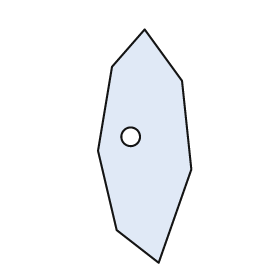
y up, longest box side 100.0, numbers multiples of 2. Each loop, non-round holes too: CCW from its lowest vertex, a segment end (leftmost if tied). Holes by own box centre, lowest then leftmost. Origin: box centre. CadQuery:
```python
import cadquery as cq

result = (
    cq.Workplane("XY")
    .moveTo(6.0, -50.0)
    .lineTo(20.0, -10.0)
    .lineTo(16.0, 28.0)
    .lineTo(0.0, 50.0)
    .lineTo(-14.0, 34.0)
    .lineTo(-20.0, -2.0)
    .lineTo(-12.0, -36.0)
    .close()
    .moveTo(-6.0, 4.0)
    .circle(4.0)
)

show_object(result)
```